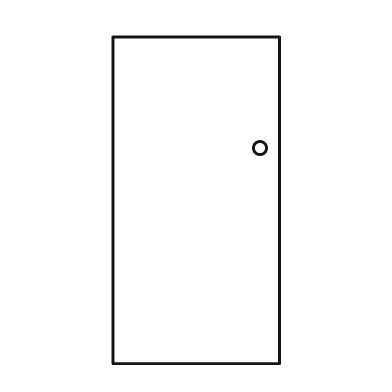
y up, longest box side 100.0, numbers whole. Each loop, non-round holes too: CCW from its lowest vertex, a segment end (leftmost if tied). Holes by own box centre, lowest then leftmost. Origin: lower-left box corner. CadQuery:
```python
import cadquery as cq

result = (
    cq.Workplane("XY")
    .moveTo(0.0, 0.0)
    .lineTo(51.0, 0.0)
    .lineTo(51.0, 100.0)
    .lineTo(0.0, 100.0)
    .close()
    .moveTo(45.0, 66.0)
    .circle(2.0)
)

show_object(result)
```